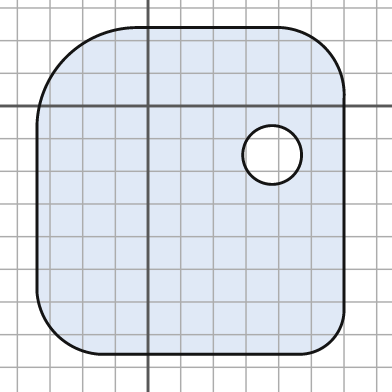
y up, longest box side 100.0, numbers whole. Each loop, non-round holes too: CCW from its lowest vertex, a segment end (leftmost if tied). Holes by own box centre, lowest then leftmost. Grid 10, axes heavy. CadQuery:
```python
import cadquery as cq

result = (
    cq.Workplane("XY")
    .moveTo(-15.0, -76.0)
    .lineTo(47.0, -76.0)
    .threePointArc((56.0, -72.0), (60.0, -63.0))
    .lineTo(60.0, 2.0)
    .threePointArc((54.0, 18.0), (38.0, 24.0))
    .lineTo(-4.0, 24.0)
    .threePointArc((-25.0, 15.0), (-34.0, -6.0))
    .lineTo(-34.0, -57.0)
    .threePointArc((-28.0, -70.0), (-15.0, -76.0))
    .close()
    .moveTo(38.0, -15.0)
    .circle(9.0)
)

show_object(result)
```